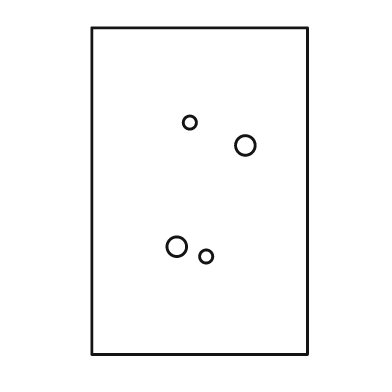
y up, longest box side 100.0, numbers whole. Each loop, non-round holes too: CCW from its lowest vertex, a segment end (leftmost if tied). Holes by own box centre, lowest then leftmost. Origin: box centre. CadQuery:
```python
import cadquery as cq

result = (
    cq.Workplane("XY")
    .moveTo(-33.0, -50.0)
    .lineTo(33.0, -50.0)
    .lineTo(33.0, 50.0)
    .lineTo(-33.0, 50.0)
    .close()
    .moveTo(2.0, -20.0)
    .circle(2.0)
    .moveTo(-7.0, -17.0)
    .circle(3.0)
    .moveTo(14.0, 14.0)
    .circle(3.0)
    .moveTo(-3.0, 21.0)
    .circle(2.0)
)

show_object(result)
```